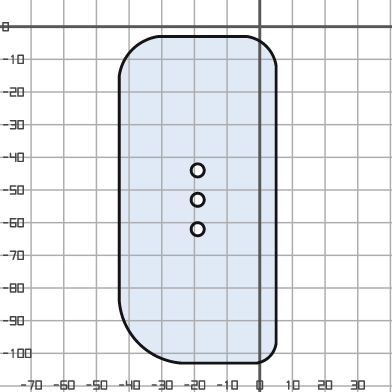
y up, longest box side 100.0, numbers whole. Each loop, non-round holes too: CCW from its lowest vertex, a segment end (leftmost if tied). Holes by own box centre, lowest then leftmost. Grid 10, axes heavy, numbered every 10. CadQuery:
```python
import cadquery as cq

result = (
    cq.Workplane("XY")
    .moveTo(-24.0, -103.0)
    .lineTo(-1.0, -103.0)
    .threePointArc((3.0, -101.0), (5.0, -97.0))
    .lineTo(5.0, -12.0)
    .threePointArc((2.0, -6.0), (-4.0, -3.0))
    .lineTo(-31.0, -3.0)
    .threePointArc((-39.0, -7.0), (-43.0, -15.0))
    .lineTo(-43.0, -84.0)
    .threePointArc((-37.0, -97.0), (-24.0, -103.0))
    .close()
    .moveTo(-19.0, -62.0)
    .circle(2.0)
    .moveTo(-19.0, -53.0)
    .circle(2.0)
    .moveTo(-19.0, -44.0)
    .circle(2.0)
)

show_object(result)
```